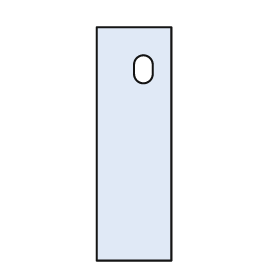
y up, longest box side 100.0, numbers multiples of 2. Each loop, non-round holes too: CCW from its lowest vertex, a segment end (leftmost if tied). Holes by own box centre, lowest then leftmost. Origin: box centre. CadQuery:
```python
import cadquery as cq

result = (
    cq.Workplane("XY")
    .moveTo(-16.0, -50.0)
    .lineTo(16.0, -50.0)
    .lineTo(16.0, 50.0)
    .lineTo(-16.0, 50.0)
    .close()
    .moveTo(0.0, 30.0)
    .threePointArc((4.0, 26.0), (8.0, 30.0))
    .lineTo(8.0, 34.0)
    .threePointArc((4.0, 38.0), (0.0, 34.0))
    .close()
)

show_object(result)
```